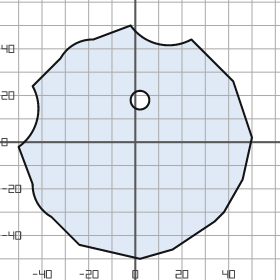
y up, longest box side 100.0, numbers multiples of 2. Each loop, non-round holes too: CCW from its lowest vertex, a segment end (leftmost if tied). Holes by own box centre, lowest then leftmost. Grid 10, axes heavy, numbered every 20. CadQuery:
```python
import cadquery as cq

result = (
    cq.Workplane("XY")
    .moveTo(2.0, -50.0)
    .lineTo(16.0, -46.0)
    .lineTo(34.0, -34.0)
    .lineTo(38.0, -30.0)
    .lineTo(46.0, -16.0)
    .lineTo(50.0, 2.0)
    .lineTo(42.0, 26.0)
    .lineTo(24.0, 44.0)
    .threePointArc((10.0, 42.0), (-2.0, 50.0))
    .lineTo(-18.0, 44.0)
    .threePointArc((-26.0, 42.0), (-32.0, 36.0))
    .lineTo(-44.0, 24.0)
    .threePointArc((-42.0, 10.0), (-50.0, -2.0))
    .lineTo(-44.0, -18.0)
    .threePointArc((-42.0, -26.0), (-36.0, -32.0))
    .lineTo(-24.0, -44.0)
    .close()
    .moveTo(2.0, 18.0)
    .circle(4.0)
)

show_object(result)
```